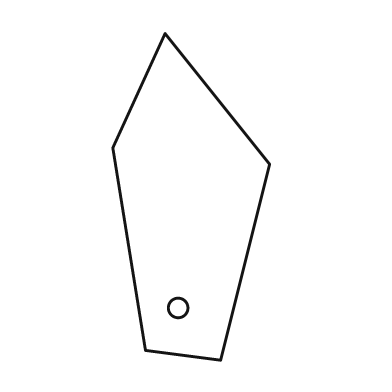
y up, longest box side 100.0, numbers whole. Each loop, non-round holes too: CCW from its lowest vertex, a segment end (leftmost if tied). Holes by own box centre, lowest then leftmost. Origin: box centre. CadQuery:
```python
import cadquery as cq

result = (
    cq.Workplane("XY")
    .moveTo(9.0, -50.0)
    .lineTo(24.0, 10.0)
    .lineTo(-8.0, 50.0)
    .lineTo(-24.0, 15.0)
    .lineTo(-14.0, -47.0)
    .close()
    .moveTo(-4.0, -34.0)
    .circle(3.0)
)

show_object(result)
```